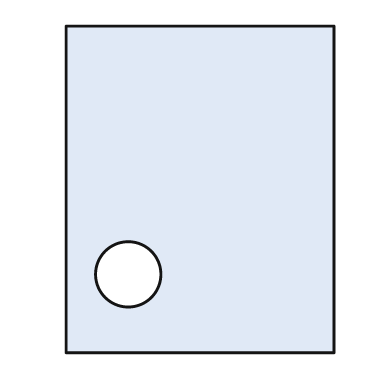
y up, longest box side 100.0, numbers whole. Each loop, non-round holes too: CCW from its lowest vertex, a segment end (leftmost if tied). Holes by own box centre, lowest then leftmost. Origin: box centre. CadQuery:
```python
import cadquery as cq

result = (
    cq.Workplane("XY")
    .moveTo(-41.0, -50.0)
    .lineTo(41.0, -50.0)
    .lineTo(41.0, 50.0)
    .lineTo(-41.0, 50.0)
    .close()
    .moveTo(-22.0, -26.0)
    .circle(10.0)
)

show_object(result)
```